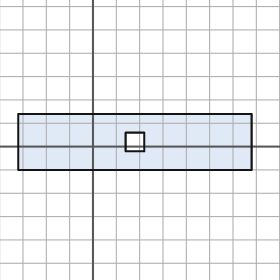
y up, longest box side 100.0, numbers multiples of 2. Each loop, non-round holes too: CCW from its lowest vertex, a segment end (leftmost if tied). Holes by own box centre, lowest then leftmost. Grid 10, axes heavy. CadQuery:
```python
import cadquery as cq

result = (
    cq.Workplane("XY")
    .moveTo(-32.0, -10.0)
    .lineTo(68.0, -10.0)
    .lineTo(68.0, 14.0)
    .lineTo(-32.0, 14.0)
    .close()
    .moveTo(14.0, -2.0)
    .lineTo(22.0, -2.0)
    .lineTo(22.0, 6.0)
    .lineTo(14.0, 6.0)
    .close()
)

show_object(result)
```